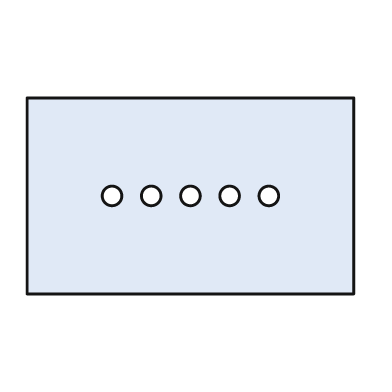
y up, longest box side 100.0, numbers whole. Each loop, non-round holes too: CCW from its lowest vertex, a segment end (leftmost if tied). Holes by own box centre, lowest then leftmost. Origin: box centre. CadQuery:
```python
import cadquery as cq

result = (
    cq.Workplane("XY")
    .moveTo(-50.0, -30.0)
    .lineTo(50.0, -30.0)
    .lineTo(50.0, 30.0)
    .lineTo(-50.0, 30.0)
    .close()
    .moveTo(-24.0, 0.0)
    .circle(3.0)
    .moveTo(-12.0, 0.0)
    .circle(3.0)
    .moveTo(0.0, 0.0)
    .circle(3.0)
    .moveTo(12.0, 0.0)
    .circle(3.0)
    .moveTo(24.0, 0.0)
    .circle(3.0)
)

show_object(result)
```